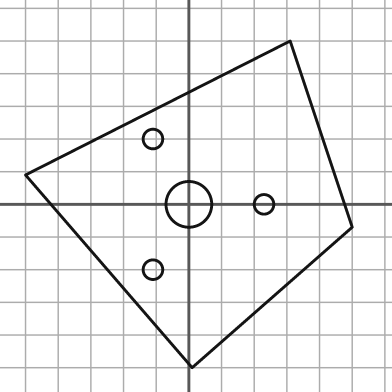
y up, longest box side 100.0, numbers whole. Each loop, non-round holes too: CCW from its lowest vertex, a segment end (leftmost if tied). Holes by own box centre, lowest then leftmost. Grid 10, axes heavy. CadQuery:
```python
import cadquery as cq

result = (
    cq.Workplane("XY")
    .moveTo(1.0, -50.0)
    .lineTo(50.0, -7.0)
    .lineTo(31.0, 50.0)
    .lineTo(-50.0, 9.0)
    .close()
    .moveTo(-11.0, -20.0)
    .circle(3.0)
    .moveTo(0.0, 0.0)
    .circle(7.0)
    .moveTo(23.0, 0.0)
    .circle(3.0)
    .moveTo(-11.0, 20.0)
    .circle(3.0)
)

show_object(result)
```